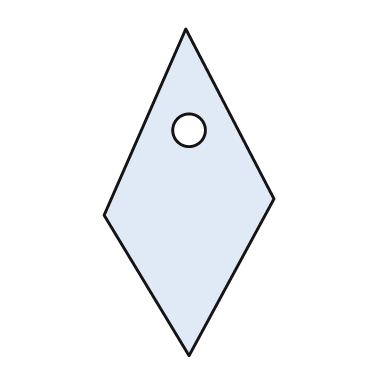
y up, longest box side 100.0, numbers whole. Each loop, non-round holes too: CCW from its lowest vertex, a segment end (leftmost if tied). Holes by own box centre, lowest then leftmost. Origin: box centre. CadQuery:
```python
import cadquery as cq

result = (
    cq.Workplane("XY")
    .moveTo(0.0, -50.0)
    .lineTo(26.0, -2.0)
    .lineTo(-1.0, 50.0)
    .lineTo(-26.0, -7.0)
    .close()
    .moveTo(0.0, 19.0)
    .circle(5.0)
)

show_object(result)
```